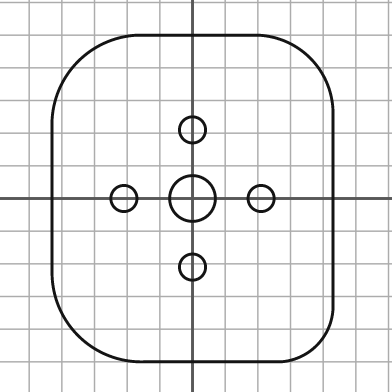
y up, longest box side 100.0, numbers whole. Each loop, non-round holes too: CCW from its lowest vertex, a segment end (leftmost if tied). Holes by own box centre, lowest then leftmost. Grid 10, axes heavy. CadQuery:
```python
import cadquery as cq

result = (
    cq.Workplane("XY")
    .moveTo(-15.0, -50.0)
    .lineTo(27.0, -50.0)
    .threePointArc((38.0, -45.0), (43.0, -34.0))
    .lineTo(43.0, 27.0)
    .threePointArc((36.0, 43.0), (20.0, 50.0))
    .lineTo(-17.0, 50.0)
    .threePointArc((-35.0, 42.0), (-43.0, 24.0))
    .lineTo(-43.0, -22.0)
    .threePointArc((-35.0, -42.0), (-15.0, -50.0))
    .close()
    .moveTo(0.0, -21.0)
    .circle(4.0)
    .moveTo(-21.0, 0.0)
    .circle(4.0)
    .moveTo(0.0, 0.0)
    .circle(7.0)
    .moveTo(21.0, 0.0)
    .circle(4.0)
    .moveTo(0.0, 21.0)
    .circle(4.0)
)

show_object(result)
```